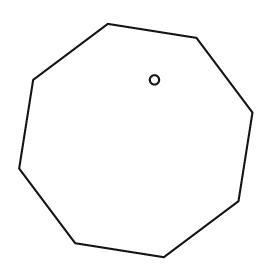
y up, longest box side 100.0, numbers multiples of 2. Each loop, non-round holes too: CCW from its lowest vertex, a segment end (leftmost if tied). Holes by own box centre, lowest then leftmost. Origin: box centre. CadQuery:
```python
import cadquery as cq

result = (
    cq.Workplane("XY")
    .moveTo(12.0, -50.0)
    .lineTo(44.0, -26.0)
    .lineTo(50.0, 12.0)
    .lineTo(26.0, 44.0)
    .lineTo(-12.0, 50.0)
    .lineTo(-44.0, 26.0)
    .lineTo(-50.0, -12.0)
    .lineTo(-26.0, -44.0)
    .close()
    .moveTo(8.0, 26.0)
    .circle(2.0)
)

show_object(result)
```